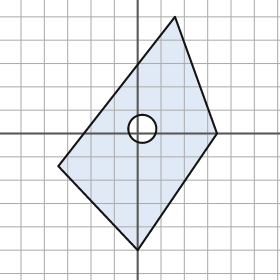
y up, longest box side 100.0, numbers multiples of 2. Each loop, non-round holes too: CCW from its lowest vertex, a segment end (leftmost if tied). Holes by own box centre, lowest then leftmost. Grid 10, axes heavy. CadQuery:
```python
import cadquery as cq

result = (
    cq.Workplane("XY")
    .moveTo(0.0, -50.0)
    .lineTo(34.0, 0.0)
    .lineTo(16.0, 50.0)
    .lineTo(-34.0, -14.0)
    .close()
    .moveTo(2.0, 2.0)
    .circle(6.0)
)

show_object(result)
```